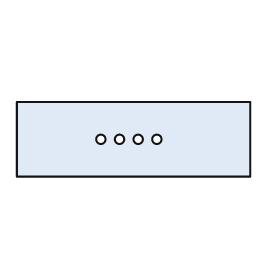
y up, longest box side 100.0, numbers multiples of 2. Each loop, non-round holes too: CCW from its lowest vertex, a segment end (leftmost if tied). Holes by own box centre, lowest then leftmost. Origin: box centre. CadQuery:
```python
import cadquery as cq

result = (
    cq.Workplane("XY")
    .moveTo(-50.0, -16.0)
    .lineTo(50.0, -16.0)
    .lineTo(50.0, 16.0)
    .lineTo(-50.0, 16.0)
    .close()
    .moveTo(-14.0, 0.0)
    .circle(2.0)
    .moveTo(-6.0, 0.0)
    .circle(2.0)
    .moveTo(2.0, 0.0)
    .circle(2.0)
    .moveTo(10.0, 0.0)
    .circle(2.0)
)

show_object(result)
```